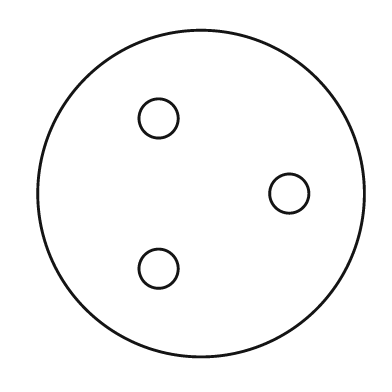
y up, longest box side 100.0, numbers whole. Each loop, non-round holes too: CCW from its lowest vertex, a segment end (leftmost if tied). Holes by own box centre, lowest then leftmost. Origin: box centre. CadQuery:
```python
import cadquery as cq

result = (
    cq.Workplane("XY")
    .moveTo(0.0, 0.0)
    .circle(50.0)
    .moveTo(-13.0, -23.0)
    .circle(6.0)
    .moveTo(27.0, 0.0)
    .circle(6.0)
    .moveTo(-13.0, 23.0)
    .circle(6.0)
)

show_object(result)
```